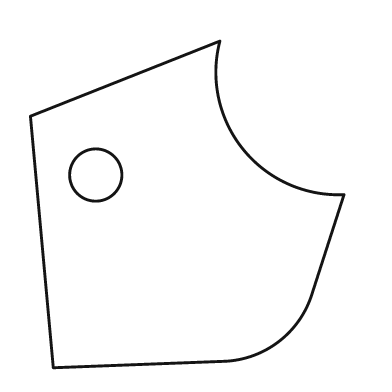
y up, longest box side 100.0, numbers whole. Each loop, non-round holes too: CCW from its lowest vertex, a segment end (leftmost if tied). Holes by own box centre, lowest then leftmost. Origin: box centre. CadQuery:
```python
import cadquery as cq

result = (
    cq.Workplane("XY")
    .moveTo(-41.0, -50.0)
    .lineTo(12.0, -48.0)
    .threePointArc((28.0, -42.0), (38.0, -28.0))
    .lineTo(48.0, 3.0)
    .threePointArc((17.0, 17.0), (10.0, 50.0))
    .lineTo(-48.0, 27.0)
    .close()
    .moveTo(-28.0, 9.0)
    .circle(8.0)
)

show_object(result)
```